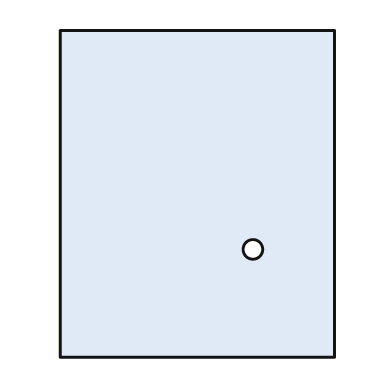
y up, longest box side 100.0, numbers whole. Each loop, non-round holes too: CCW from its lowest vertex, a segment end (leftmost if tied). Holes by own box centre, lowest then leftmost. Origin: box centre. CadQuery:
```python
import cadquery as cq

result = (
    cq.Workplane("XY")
    .moveTo(-42.0, -50.0)
    .lineTo(42.0, -50.0)
    .lineTo(42.0, 50.0)
    .lineTo(-42.0, 50.0)
    .close()
    .moveTo(17.0, -17.0)
    .circle(3.0)
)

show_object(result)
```